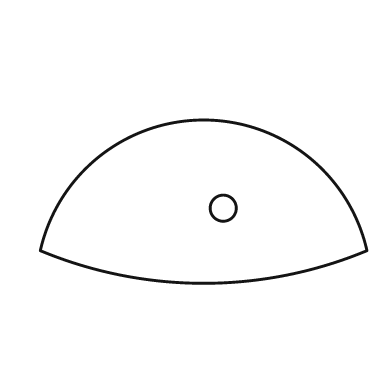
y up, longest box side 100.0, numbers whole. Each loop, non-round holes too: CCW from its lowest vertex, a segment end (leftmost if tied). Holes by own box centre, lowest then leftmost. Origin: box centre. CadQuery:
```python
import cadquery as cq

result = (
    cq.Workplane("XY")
    .moveTo(-50.0, -15.0)
    .threePointArc((0.0, -25.0), (50.0, -15.0))
    .threePointArc((0.0, 25.0), (-50.0, -15.0))
    .close()
    .moveTo(6.0, -2.0)
    .circle(4.0)
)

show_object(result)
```